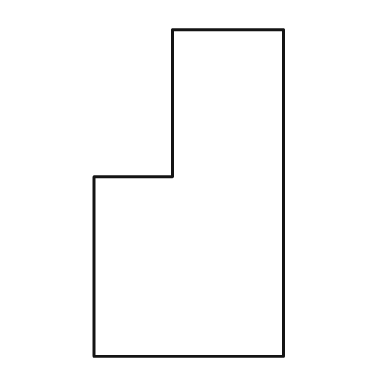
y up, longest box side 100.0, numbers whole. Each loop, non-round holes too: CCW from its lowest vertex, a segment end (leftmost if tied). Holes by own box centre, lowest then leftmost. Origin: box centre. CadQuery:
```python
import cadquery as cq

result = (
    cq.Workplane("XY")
    .moveTo(-29.0, -50.0)
    .lineTo(29.0, -50.0)
    .lineTo(29.0, 50.0)
    .lineTo(-5.0, 50.0)
    .lineTo(-5.0, 5.0)
    .lineTo(-29.0, 5.0)
    .close()
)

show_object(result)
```